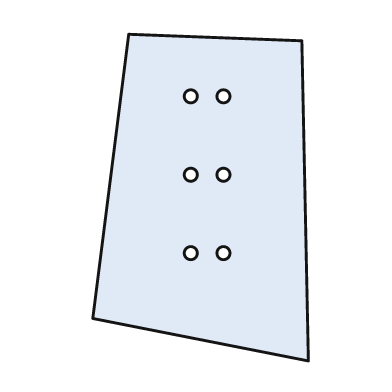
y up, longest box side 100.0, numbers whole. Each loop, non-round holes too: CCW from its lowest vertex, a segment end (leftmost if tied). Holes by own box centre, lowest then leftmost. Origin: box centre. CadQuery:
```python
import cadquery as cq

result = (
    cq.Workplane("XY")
    .moveTo(33.0, -50.0)
    .lineTo(31.0, 48.0)
    .lineTo(-22.0, 50.0)
    .lineTo(-33.0, -37.0)
    .close()
    .moveTo(-3.0, -17.0)
    .circle(2.0)
    .moveTo(7.0, -17.0)
    .circle(2.0)
    .moveTo(-3.0, 7.0)
    .circle(2.0)
    .moveTo(7.0, 7.0)
    .circle(2.0)
    .moveTo(-3.0, 31.0)
    .circle(2.0)
    .moveTo(7.0, 31.0)
    .circle(2.0)
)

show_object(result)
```